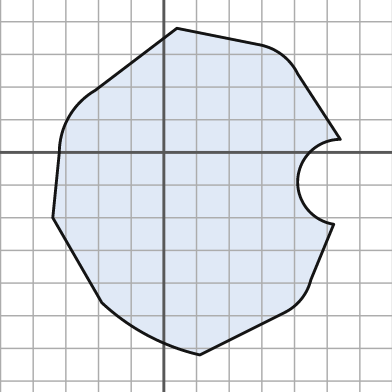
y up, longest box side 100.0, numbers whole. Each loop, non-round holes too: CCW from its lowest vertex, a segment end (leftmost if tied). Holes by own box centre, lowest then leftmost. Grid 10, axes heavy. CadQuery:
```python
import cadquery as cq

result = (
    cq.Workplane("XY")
    .moveTo(11.0, -62.0)
    .lineTo(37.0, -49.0)
    .threePointArc((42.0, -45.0), (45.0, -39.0))
    .lineTo(52.0, -22.0)
    .threePointArc((41.0, -8.0), (54.0, 4.0))
    .lineTo(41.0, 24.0)
    .threePointArc((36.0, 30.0), (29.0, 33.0))
    .lineTo(4.0, 38.0)
    .lineTo(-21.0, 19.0)
    .threePointArc((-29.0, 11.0), (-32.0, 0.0))
    .lineTo(-34.0, -20.0)
    .lineTo(-19.0, -46.0)
    .threePointArc((-5.0, -56.0), (11.0, -62.0))
    .close()
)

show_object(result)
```